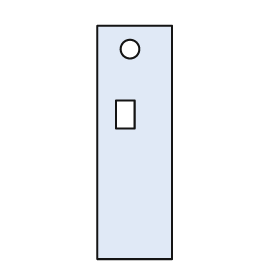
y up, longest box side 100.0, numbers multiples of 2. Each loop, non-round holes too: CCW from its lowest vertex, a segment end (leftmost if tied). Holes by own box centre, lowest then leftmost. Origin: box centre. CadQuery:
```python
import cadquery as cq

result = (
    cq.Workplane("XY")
    .moveTo(-16.0, -50.0)
    .lineTo(16.0, -50.0)
    .lineTo(16.0, 50.0)
    .lineTo(-16.0, 50.0)
    .close()
    .moveTo(-8.0, 6.0)
    .lineTo(0.0, 6.0)
    .lineTo(0.0, 18.0)
    .lineTo(-8.0, 18.0)
    .close()
    .moveTo(-2.0, 40.0)
    .circle(4.0)
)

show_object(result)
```